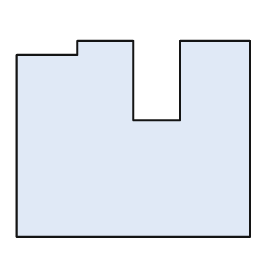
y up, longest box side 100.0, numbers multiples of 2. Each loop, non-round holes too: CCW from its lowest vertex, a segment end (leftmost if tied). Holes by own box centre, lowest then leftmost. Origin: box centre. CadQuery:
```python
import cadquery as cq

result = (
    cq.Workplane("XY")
    .moveTo(-50.0, -42.0)
    .lineTo(50.0, -42.0)
    .lineTo(50.0, 42.0)
    .lineTo(20.0, 42.0)
    .lineTo(20.0, 8.0)
    .lineTo(0.0, 8.0)
    .lineTo(0.0, 42.0)
    .lineTo(-24.0, 42.0)
    .lineTo(-24.0, 36.0)
    .lineTo(-50.0, 36.0)
    .close()
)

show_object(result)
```